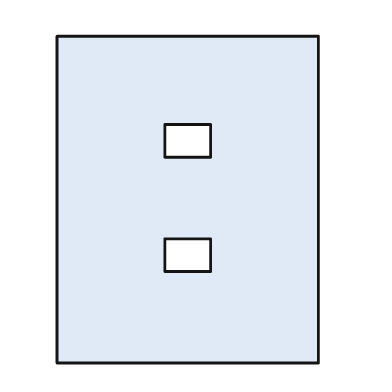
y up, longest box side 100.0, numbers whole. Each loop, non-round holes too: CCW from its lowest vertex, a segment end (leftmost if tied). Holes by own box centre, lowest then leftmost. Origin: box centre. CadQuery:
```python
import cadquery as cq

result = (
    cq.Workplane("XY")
    .moveTo(-40.0, -50.0)
    .lineTo(40.0, -50.0)
    .lineTo(40.0, 50.0)
    .lineTo(-40.0, 50.0)
    .close()
    .moveTo(-7.0, -22.0)
    .lineTo(7.0, -22.0)
    .lineTo(7.0, -12.0)
    .lineTo(-7.0, -12.0)
    .close()
    .moveTo(-7.0, 13.0)
    .lineTo(7.0, 13.0)
    .lineTo(7.0, 23.0)
    .lineTo(-7.0, 23.0)
    .close()
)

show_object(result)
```